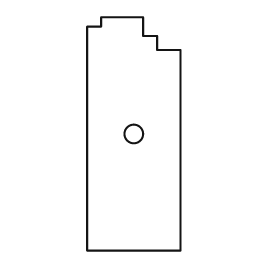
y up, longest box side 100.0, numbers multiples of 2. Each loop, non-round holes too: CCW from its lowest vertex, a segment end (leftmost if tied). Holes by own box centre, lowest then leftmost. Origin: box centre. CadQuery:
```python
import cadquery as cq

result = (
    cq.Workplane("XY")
    .moveTo(-20.0, -50.0)
    .lineTo(20.0, -50.0)
    .lineTo(20.0, 36.0)
    .lineTo(10.0, 36.0)
    .lineTo(10.0, 42.0)
    .lineTo(4.0, 42.0)
    .lineTo(4.0, 50.0)
    .lineTo(-14.0, 50.0)
    .lineTo(-14.0, 46.0)
    .lineTo(-20.0, 46.0)
    .close()
    .moveTo(0.0, 0.0)
    .circle(4.0)
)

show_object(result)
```